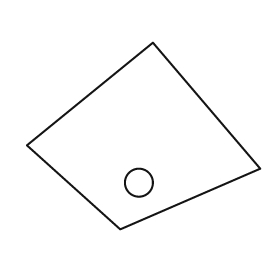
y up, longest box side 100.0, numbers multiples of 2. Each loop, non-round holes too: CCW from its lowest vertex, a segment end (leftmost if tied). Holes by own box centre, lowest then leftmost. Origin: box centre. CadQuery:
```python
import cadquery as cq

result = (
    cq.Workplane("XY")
    .moveTo(-10.0, -40.0)
    .lineTo(50.0, -14.0)
    .lineTo(4.0, 40.0)
    .lineTo(-50.0, -4.0)
    .close()
    .moveTo(-2.0, -20.0)
    .circle(6.0)
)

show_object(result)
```